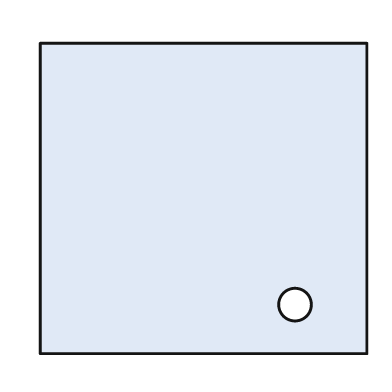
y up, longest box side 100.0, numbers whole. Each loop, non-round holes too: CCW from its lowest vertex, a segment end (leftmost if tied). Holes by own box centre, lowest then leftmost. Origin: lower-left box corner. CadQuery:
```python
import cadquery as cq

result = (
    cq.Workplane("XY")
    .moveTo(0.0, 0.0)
    .lineTo(100.0, 0.0)
    .lineTo(100.0, 95.0)
    .lineTo(0.0, 95.0)
    .close()
    .moveTo(78.0, 15.0)
    .circle(5.0)
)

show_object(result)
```